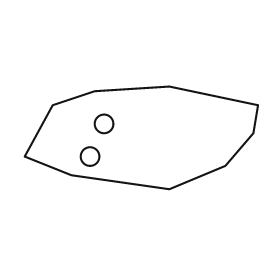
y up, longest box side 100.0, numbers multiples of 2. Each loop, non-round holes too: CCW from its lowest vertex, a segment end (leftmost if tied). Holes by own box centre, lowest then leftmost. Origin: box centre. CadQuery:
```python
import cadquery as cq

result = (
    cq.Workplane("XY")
    .moveTo(12.0, -22.0)
    .lineTo(36.0, -12.0)
    .lineTo(48.0, 2.0)
    .lineTo(50.0, 14.0)
    .lineTo(12.0, 22.0)
    .lineTo(-20.0, 20.0)
    .lineTo(-38.0, 14.0)
    .lineTo(-50.0, -8.0)
    .lineTo(-30.0, -16.0)
    .close()
    .moveTo(-22.0, -8.0)
    .circle(4.0)
    .moveTo(-16.0, 6.0)
    .circle(4.0)
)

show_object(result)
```